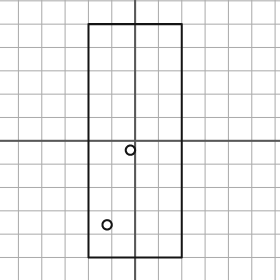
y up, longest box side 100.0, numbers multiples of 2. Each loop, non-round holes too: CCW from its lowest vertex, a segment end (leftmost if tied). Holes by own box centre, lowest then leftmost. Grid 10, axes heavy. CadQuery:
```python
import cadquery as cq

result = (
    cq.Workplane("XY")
    .moveTo(-20.0, -50.0)
    .lineTo(20.0, -50.0)
    .lineTo(20.0, 50.0)
    .lineTo(-20.0, 50.0)
    .close()
    .moveTo(-12.0, -36.0)
    .circle(2.0)
    .moveTo(-2.0, -4.0)
    .circle(2.0)
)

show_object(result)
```